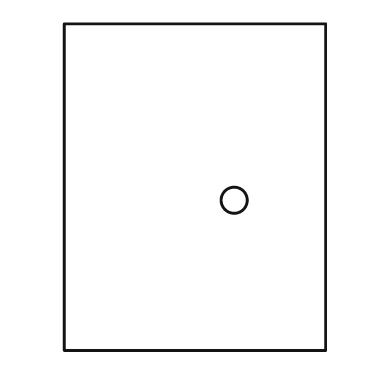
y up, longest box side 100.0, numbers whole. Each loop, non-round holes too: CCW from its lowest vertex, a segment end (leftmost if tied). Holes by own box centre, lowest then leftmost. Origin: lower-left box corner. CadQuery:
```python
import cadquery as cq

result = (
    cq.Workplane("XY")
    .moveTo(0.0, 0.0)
    .lineTo(80.0, 0.0)
    .lineTo(80.0, 100.0)
    .lineTo(0.0, 100.0)
    .close()
    .moveTo(52.0, 46.0)
    .circle(4.0)
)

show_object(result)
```